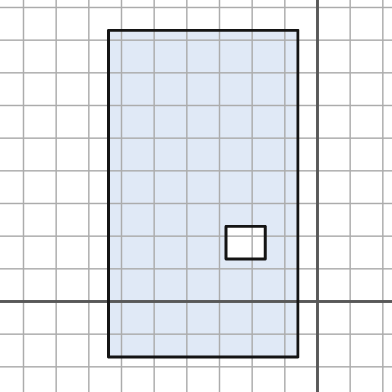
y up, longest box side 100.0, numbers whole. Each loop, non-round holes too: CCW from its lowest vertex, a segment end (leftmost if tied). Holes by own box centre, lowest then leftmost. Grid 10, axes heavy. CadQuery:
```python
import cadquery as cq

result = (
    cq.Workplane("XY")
    .moveTo(-64.0, -17.0)
    .lineTo(-6.0, -17.0)
    .lineTo(-6.0, 83.0)
    .lineTo(-64.0, 83.0)
    .close()
    .moveTo(-28.0, 13.0)
    .lineTo(-16.0, 13.0)
    .lineTo(-16.0, 23.0)
    .lineTo(-28.0, 23.0)
    .close()
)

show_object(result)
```